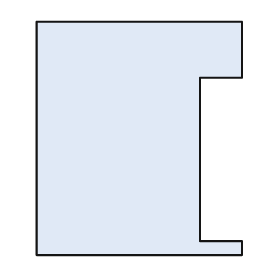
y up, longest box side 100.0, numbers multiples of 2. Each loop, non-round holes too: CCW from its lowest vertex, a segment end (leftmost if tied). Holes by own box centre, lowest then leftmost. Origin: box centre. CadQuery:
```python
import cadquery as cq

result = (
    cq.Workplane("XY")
    .moveTo(-44.0, -50.0)
    .lineTo(44.0, -50.0)
    .lineTo(44.0, -44.0)
    .lineTo(26.0, -44.0)
    .lineTo(26.0, 26.0)
    .lineTo(44.0, 26.0)
    .lineTo(44.0, 50.0)
    .lineTo(-44.0, 50.0)
    .close()
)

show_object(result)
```